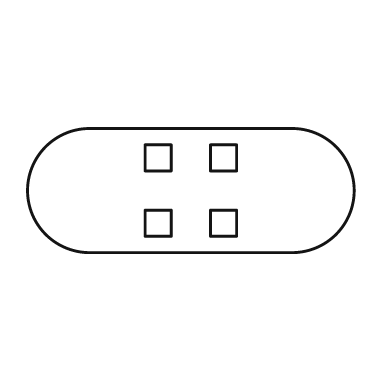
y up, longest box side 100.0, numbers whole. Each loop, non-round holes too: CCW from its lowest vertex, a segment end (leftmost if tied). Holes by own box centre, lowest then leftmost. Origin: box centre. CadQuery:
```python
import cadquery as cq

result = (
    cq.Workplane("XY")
    .moveTo(-31.0, -19.0)
    .lineTo(31.0, -19.0)
    .threePointArc((50.0, 0.0), (31.0, 19.0))
    .lineTo(-31.0, 19.0)
    .threePointArc((-50.0, 0.0), (-31.0, -19.0))
    .close()
    .moveTo(-14.0, -14.0)
    .lineTo(-6.0, -14.0)
    .lineTo(-6.0, -6.0)
    .lineTo(-14.0, -6.0)
    .close()
    .moveTo(6.0, -14.0)
    .lineTo(14.0, -14.0)
    .lineTo(14.0, -6.0)
    .lineTo(6.0, -6.0)
    .close()
    .moveTo(-14.0, 6.0)
    .lineTo(-6.0, 6.0)
    .lineTo(-6.0, 14.0)
    .lineTo(-14.0, 14.0)
    .close()
    .moveTo(6.0, 6.0)
    .lineTo(14.0, 6.0)
    .lineTo(14.0, 14.0)
    .lineTo(6.0, 14.0)
    .close()
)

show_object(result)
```